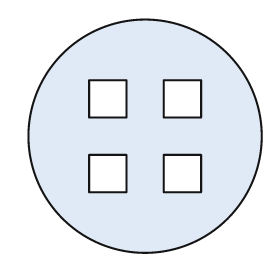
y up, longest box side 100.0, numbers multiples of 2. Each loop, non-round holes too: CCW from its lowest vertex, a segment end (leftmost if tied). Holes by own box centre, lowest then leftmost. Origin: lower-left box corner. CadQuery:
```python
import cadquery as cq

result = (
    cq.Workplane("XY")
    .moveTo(50.0, 50.0)
    .circle(50.0)
    .moveTo(26.0, 26.0)
    .lineTo(42.0, 26.0)
    .lineTo(42.0, 42.0)
    .lineTo(26.0, 42.0)
    .close()
    .moveTo(58.0, 26.0)
    .lineTo(74.0, 26.0)
    .lineTo(74.0, 42.0)
    .lineTo(58.0, 42.0)
    .close()
    .moveTo(26.0, 58.0)
    .lineTo(42.0, 58.0)
    .lineTo(42.0, 74.0)
    .lineTo(26.0, 74.0)
    .close()
    .moveTo(58.0, 58.0)
    .lineTo(74.0, 58.0)
    .lineTo(74.0, 74.0)
    .lineTo(58.0, 74.0)
    .close()
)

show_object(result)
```